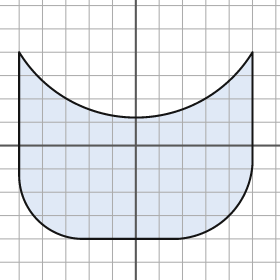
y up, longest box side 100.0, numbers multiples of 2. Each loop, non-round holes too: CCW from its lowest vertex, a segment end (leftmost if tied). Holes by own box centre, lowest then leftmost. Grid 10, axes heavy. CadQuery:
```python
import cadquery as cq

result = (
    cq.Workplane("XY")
    .moveTo(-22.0, -40.0)
    .lineTo(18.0, -40.0)
    .threePointArc((40.0, -30.0), (50.0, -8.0))
    .lineTo(50.0, 40.0)
    .threePointArc((0.0, 12.0), (-50.0, 40.0))
    .lineTo(-50.0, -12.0)
    .threePointArc((-42.0, -32.0), (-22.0, -40.0))
    .close()
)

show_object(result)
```